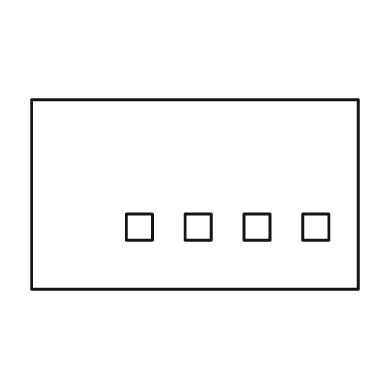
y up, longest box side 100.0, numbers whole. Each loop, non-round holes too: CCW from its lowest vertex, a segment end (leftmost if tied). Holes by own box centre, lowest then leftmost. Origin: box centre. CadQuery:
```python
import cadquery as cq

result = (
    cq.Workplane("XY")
    .moveTo(-50.0, -29.0)
    .lineTo(50.0, -29.0)
    .lineTo(50.0, 29.0)
    .lineTo(-50.0, 29.0)
    .close()
    .moveTo(-21.0, -14.0)
    .lineTo(-13.0, -14.0)
    .lineTo(-13.0, -6.0)
    .lineTo(-21.0, -6.0)
    .close()
    .moveTo(-3.0, -14.0)
    .lineTo(5.0, -14.0)
    .lineTo(5.0, -6.0)
    .lineTo(-3.0, -6.0)
    .close()
    .moveTo(15.0, -14.0)
    .lineTo(23.0, -14.0)
    .lineTo(23.0, -6.0)
    .lineTo(15.0, -6.0)
    .close()
    .moveTo(33.0, -14.0)
    .lineTo(41.0, -14.0)
    .lineTo(41.0, -6.0)
    .lineTo(33.0, -6.0)
    .close()
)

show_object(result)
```